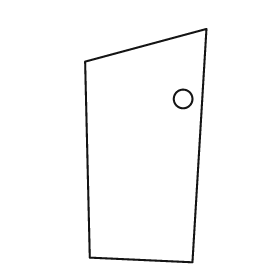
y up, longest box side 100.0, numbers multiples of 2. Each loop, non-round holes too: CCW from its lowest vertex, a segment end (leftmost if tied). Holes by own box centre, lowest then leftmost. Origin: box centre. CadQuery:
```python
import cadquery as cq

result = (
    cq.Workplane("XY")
    .moveTo(20.0, -50.0)
    .lineTo(26.0, 50.0)
    .lineTo(-26.0, 36.0)
    .lineTo(-24.0, -48.0)
    .close()
    .moveTo(16.0, 20.0)
    .circle(4.0)
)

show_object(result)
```